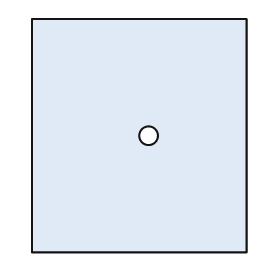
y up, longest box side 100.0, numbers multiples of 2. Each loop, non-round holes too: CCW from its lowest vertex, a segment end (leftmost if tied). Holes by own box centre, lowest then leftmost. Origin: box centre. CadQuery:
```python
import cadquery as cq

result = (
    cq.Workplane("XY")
    .moveTo(-46.0, -50.0)
    .lineTo(46.0, -50.0)
    .lineTo(46.0, 50.0)
    .lineTo(-46.0, 50.0)
    .close()
    .moveTo(4.0, 0.0)
    .circle(4.0)
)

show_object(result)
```